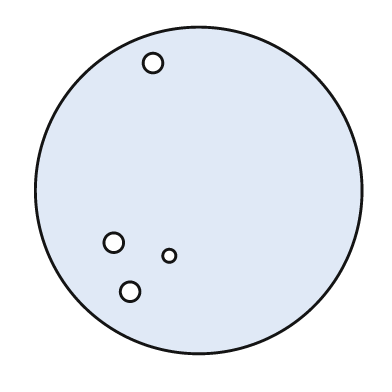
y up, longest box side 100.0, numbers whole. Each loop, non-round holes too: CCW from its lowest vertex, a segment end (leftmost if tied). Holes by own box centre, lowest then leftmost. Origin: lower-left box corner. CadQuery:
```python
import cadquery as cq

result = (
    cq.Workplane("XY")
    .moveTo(50.0, 50.0)
    .circle(50.0)
    .moveTo(29.0, 19.0)
    .circle(3.0)
    .moveTo(41.0, 30.0)
    .circle(2.0)
    .moveTo(24.0, 34.0)
    .circle(3.0)
    .moveTo(36.0, 89.0)
    .circle(3.0)
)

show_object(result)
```